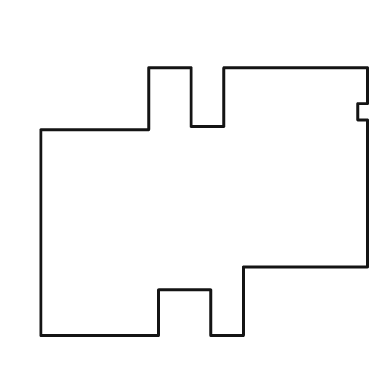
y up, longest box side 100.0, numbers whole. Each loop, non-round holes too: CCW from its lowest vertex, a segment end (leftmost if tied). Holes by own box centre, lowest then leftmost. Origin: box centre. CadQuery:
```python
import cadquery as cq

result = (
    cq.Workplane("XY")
    .moveTo(-50.0, -41.0)
    .lineTo(-14.0, -41.0)
    .lineTo(-14.0, -27.0)
    .lineTo(2.0, -27.0)
    .lineTo(2.0, -41.0)
    .lineTo(12.0, -41.0)
    .lineTo(12.0, -20.0)
    .lineTo(50.0, -20.0)
    .lineTo(50.0, 25.0)
    .lineTo(47.0, 25.0)
    .lineTo(47.0, 30.0)
    .lineTo(50.0, 30.0)
    .lineTo(50.0, 41.0)
    .lineTo(6.0, 41.0)
    .lineTo(6.0, 23.0)
    .lineTo(-4.0, 23.0)
    .lineTo(-4.0, 41.0)
    .lineTo(-17.0, 41.0)
    .lineTo(-17.0, 22.0)
    .lineTo(-50.0, 22.0)
    .close()
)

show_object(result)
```